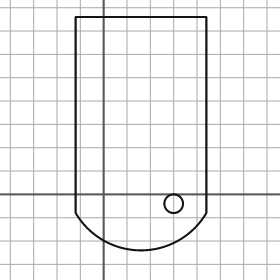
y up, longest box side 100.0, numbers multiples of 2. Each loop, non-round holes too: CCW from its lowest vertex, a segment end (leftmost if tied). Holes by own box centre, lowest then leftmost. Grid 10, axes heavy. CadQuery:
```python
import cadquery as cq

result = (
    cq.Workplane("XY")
    .moveTo(-12.0, -8.0)
    .threePointArc((16.0, -24.0), (44.0, -8.0))
    .lineTo(44.0, 76.0)
    .lineTo(-12.0, 76.0)
    .close()
    .moveTo(30.0, -4.0)
    .circle(4.0)
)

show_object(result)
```